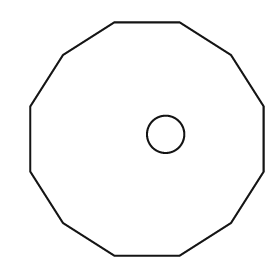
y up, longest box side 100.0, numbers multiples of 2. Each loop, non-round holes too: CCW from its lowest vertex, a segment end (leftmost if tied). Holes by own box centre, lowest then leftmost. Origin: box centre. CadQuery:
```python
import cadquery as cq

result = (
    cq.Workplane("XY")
    .moveTo(-14.0, -50.0)
    .lineTo(14.0, -50.0)
    .lineTo(36.0, -36.0)
    .lineTo(50.0, -14.0)
    .lineTo(50.0, 14.0)
    .lineTo(36.0, 36.0)
    .lineTo(14.0, 50.0)
    .lineTo(-14.0, 50.0)
    .lineTo(-36.0, 36.0)
    .lineTo(-50.0, 14.0)
    .lineTo(-50.0, -14.0)
    .lineTo(-36.0, -36.0)
    .close()
    .moveTo(8.0, 2.0)
    .circle(8.0)
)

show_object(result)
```